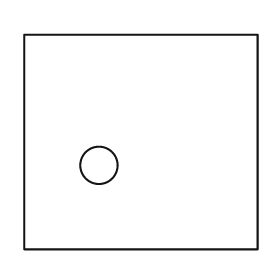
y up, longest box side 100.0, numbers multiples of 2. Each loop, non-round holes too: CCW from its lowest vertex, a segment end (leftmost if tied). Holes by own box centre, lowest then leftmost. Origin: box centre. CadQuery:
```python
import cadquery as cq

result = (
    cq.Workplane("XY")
    .moveTo(-50.0, -46.0)
    .lineTo(50.0, -46.0)
    .lineTo(50.0, 46.0)
    .lineTo(-50.0, 46.0)
    .close()
    .moveTo(-18.0, -10.0)
    .circle(8.0)
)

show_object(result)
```